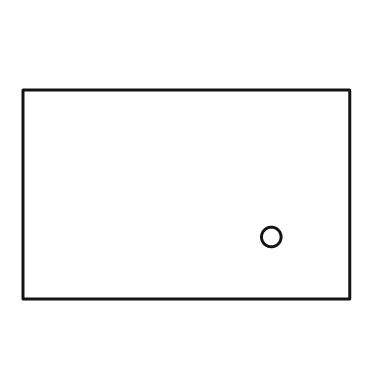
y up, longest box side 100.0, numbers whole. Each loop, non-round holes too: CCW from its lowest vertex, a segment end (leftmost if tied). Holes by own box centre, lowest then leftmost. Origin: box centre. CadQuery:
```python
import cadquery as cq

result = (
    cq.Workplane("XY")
    .moveTo(-50.0, -32.0)
    .lineTo(50.0, -32.0)
    .lineTo(50.0, 32.0)
    .lineTo(-50.0, 32.0)
    .close()
    .moveTo(26.0, -13.0)
    .circle(3.0)
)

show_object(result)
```